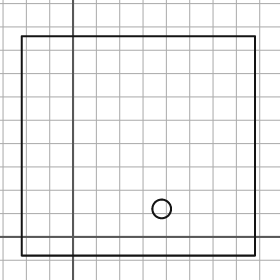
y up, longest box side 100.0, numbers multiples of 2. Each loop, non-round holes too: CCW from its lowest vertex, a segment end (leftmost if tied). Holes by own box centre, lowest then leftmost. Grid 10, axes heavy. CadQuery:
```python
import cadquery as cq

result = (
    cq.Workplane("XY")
    .moveTo(-22.0, -8.0)
    .lineTo(78.0, -8.0)
    .lineTo(78.0, 86.0)
    .lineTo(-22.0, 86.0)
    .close()
    .moveTo(38.0, 12.0)
    .circle(4.0)
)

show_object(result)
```